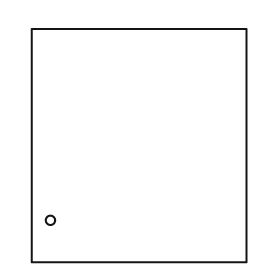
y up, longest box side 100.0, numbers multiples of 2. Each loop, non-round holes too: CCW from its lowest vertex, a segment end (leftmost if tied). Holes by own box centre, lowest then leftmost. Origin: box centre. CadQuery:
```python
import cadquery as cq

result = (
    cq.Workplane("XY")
    .moveTo(-46.0, -50.0)
    .lineTo(46.0, -50.0)
    .lineTo(46.0, 50.0)
    .lineTo(-46.0, 50.0)
    .close()
    .moveTo(-38.0, -32.0)
    .circle(2.0)
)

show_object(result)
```